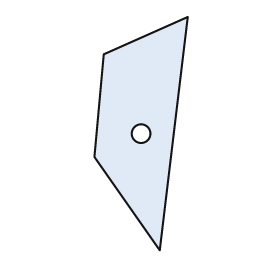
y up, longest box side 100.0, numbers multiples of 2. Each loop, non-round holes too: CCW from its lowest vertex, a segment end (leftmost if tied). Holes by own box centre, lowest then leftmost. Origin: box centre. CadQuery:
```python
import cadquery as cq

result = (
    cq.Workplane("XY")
    .moveTo(8.0, -50.0)
    .lineTo(20.0, 50.0)
    .lineTo(-16.0, 34.0)
    .lineTo(-20.0, -10.0)
    .close()
    .moveTo(0.0, 0.0)
    .circle(4.0)
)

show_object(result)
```